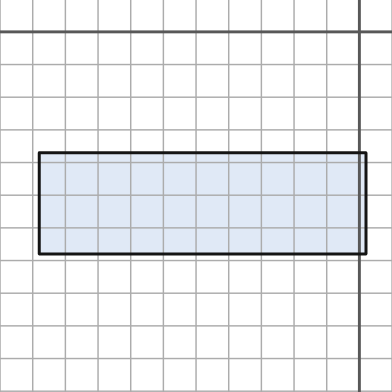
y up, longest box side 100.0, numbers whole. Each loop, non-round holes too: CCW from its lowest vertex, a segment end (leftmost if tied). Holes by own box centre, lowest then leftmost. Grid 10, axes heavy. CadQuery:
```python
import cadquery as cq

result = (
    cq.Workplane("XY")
    .moveTo(-98.0, -68.0)
    .lineTo(2.0, -68.0)
    .lineTo(2.0, -37.0)
    .lineTo(-98.0, -37.0)
    .close()
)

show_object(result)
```